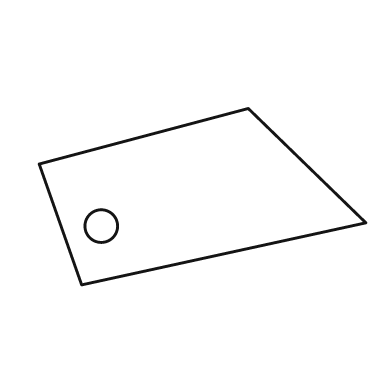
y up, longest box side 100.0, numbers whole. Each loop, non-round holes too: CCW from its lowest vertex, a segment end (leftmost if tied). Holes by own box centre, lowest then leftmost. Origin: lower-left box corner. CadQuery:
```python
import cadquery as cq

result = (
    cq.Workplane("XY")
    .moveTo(13.0, 0.0)
    .lineTo(100.0, 19.0)
    .lineTo(64.0, 54.0)
    .lineTo(0.0, 37.0)
    .close()
    .moveTo(19.0, 18.0)
    .circle(5.0)
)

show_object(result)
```